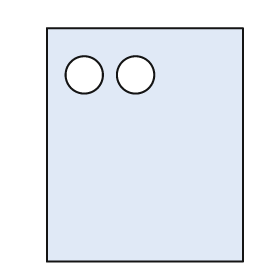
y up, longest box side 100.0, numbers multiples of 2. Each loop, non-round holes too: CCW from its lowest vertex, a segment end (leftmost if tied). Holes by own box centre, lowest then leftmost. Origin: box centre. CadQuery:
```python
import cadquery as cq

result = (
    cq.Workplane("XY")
    .moveTo(-42.0, -50.0)
    .lineTo(42.0, -50.0)
    .lineTo(42.0, 50.0)
    .lineTo(-42.0, 50.0)
    .close()
    .moveTo(-26.0, 30.0)
    .circle(8.0)
    .moveTo(-4.0, 30.0)
    .circle(8.0)
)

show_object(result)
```